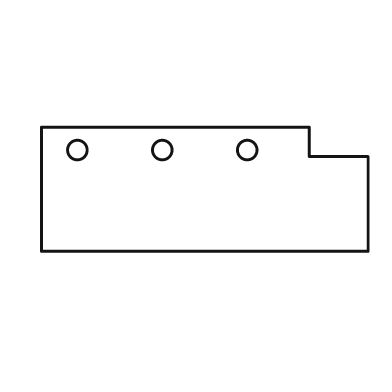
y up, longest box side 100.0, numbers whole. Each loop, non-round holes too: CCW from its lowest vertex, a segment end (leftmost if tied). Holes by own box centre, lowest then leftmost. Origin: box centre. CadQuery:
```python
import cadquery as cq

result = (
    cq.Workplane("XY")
    .moveTo(-50.0, -19.0)
    .lineTo(50.0, -19.0)
    .lineTo(50.0, 10.0)
    .lineTo(32.0, 10.0)
    .lineTo(32.0, 19.0)
    .lineTo(-50.0, 19.0)
    .close()
    .moveTo(-39.0, 12.0)
    .circle(3.0)
    .moveTo(-13.0, 12.0)
    .circle(3.0)
    .moveTo(13.0, 12.0)
    .circle(3.0)
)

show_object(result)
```